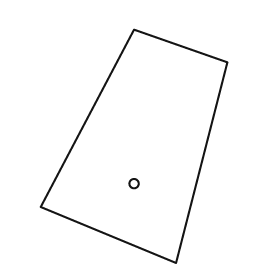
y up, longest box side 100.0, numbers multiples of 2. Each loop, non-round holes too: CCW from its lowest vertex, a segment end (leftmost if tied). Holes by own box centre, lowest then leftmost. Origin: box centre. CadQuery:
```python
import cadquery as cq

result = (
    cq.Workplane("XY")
    .moveTo(18.0, -50.0)
    .lineTo(40.0, 36.0)
    .lineTo(0.0, 50.0)
    .lineTo(-40.0, -26.0)
    .close()
    .moveTo(0.0, -16.0)
    .circle(2.0)
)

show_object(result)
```